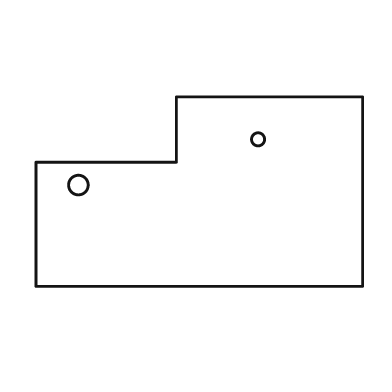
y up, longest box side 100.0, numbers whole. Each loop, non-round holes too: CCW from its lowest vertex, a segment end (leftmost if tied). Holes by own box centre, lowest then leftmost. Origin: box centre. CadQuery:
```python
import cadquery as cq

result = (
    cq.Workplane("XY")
    .moveTo(-50.0, -29.0)
    .lineTo(50.0, -29.0)
    .lineTo(50.0, 29.0)
    .lineTo(-7.0, 29.0)
    .lineTo(-7.0, 9.0)
    .lineTo(-50.0, 9.0)
    .close()
    .moveTo(-37.0, 2.0)
    .circle(3.0)
    .moveTo(18.0, 16.0)
    .circle(2.0)
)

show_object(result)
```